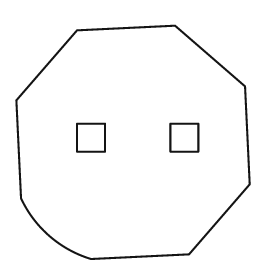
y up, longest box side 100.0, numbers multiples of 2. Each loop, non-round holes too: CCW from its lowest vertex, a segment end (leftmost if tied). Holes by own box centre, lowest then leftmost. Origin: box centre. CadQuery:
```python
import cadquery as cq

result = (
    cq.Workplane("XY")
    .moveTo(-18.0, -50.0)
    .lineTo(24.0, -48.0)
    .lineTo(50.0, -18.0)
    .lineTo(48.0, 24.0)
    .lineTo(18.0, 50.0)
    .lineTo(-24.0, 48.0)
    .lineTo(-50.0, 18.0)
    .lineTo(-48.0, -24.0)
    .threePointArc((-36.0, -40.0), (-18.0, -50.0))
    .close()
    .moveTo(-24.0, -4.0)
    .lineTo(-12.0, -4.0)
    .lineTo(-12.0, 8.0)
    .lineTo(-24.0, 8.0)
    .close()
    .moveTo(16.0, -4.0)
    .lineTo(28.0, -4.0)
    .lineTo(28.0, 8.0)
    .lineTo(16.0, 8.0)
    .close()
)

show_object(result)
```